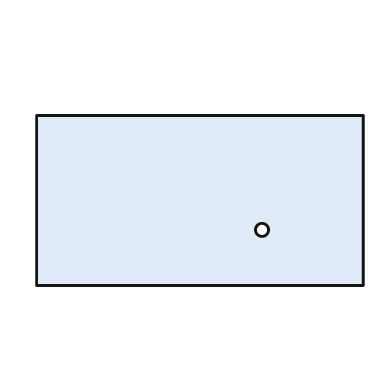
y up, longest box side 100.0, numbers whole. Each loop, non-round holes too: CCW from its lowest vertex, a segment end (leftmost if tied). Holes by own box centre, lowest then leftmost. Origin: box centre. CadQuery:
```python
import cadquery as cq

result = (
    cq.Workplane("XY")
    .moveTo(-50.0, -26.0)
    .lineTo(50.0, -26.0)
    .lineTo(50.0, 26.0)
    .lineTo(-50.0, 26.0)
    .close()
    .moveTo(19.0, -9.0)
    .circle(2.0)
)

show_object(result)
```